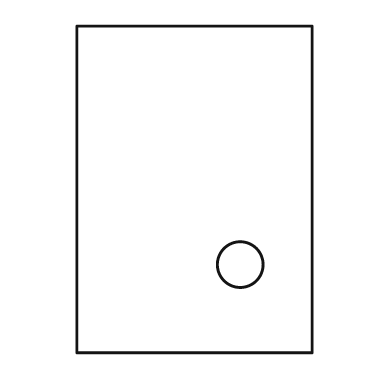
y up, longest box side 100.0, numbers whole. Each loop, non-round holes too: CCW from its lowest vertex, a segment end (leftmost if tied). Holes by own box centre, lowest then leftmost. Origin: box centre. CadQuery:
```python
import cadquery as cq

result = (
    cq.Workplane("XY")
    .moveTo(-36.0, -50.0)
    .lineTo(36.0, -50.0)
    .lineTo(36.0, 50.0)
    .lineTo(-36.0, 50.0)
    .close()
    .moveTo(14.0, -23.0)
    .circle(7.0)
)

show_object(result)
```